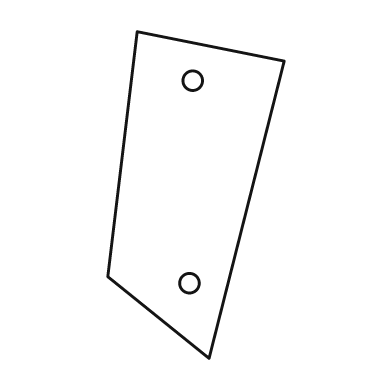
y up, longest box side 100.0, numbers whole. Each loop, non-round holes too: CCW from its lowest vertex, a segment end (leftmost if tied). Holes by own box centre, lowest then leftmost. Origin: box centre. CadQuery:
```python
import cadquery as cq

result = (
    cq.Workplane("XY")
    .moveTo(4.0, -50.0)
    .lineTo(27.0, 41.0)
    .lineTo(-18.0, 50.0)
    .lineTo(-27.0, -25.0)
    .close()
    .moveTo(-2.0, -27.0)
    .circle(3.0)
    .moveTo(-1.0, 35.0)
    .circle(3.0)
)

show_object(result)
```